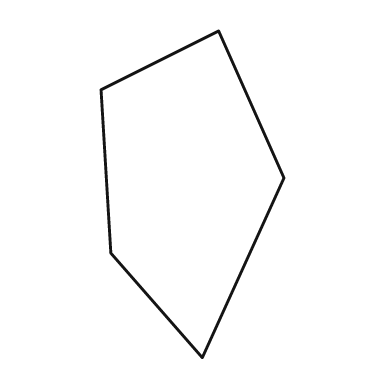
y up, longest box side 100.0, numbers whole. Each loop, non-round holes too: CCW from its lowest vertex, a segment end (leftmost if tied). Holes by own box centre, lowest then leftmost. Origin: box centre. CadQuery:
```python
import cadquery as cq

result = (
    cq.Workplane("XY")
    .moveTo(3.0, -50.0)
    .lineTo(28.0, 5.0)
    .lineTo(8.0, 50.0)
    .lineTo(-28.0, 32.0)
    .lineTo(-25.0, -18.0)
    .close()
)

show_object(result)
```